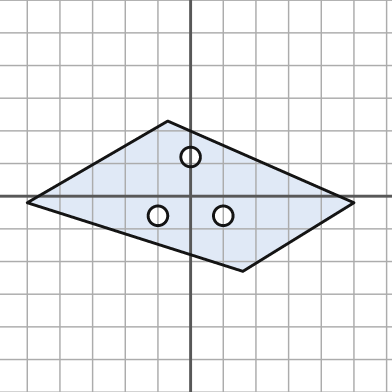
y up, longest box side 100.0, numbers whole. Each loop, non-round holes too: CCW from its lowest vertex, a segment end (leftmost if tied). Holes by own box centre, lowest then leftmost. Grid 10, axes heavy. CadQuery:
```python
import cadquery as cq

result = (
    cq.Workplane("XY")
    .moveTo(16.0, -23.0)
    .lineTo(50.0, -2.0)
    .lineTo(-7.0, 23.0)
    .lineTo(-50.0, -2.0)
    .close()
    .moveTo(-10.0, -6.0)
    .circle(3.0)
    .moveTo(10.0, -6.0)
    .circle(3.0)
    .moveTo(0.0, 12.0)
    .circle(3.0)
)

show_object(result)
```